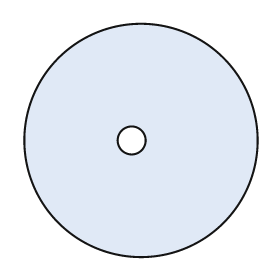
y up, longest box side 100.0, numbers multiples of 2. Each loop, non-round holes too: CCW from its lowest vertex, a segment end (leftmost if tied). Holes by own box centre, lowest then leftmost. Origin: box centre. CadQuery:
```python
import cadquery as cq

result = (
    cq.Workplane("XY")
    .moveTo(0.0, 0.0)
    .circle(50.0)
    .moveTo(-4.0, 0.0)
    .circle(6.0)
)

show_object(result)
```